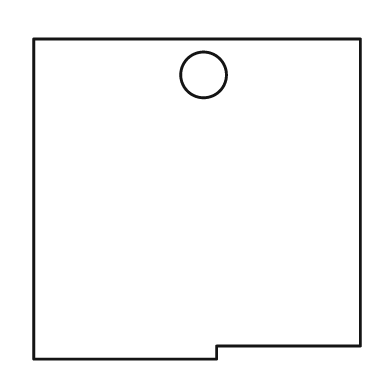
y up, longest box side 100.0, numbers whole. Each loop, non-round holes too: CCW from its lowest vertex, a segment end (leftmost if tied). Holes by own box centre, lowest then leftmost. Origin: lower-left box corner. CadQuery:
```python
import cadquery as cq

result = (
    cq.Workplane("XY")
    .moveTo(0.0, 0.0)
    .lineTo(56.0, 0.0)
    .lineTo(56.0, 4.0)
    .lineTo(100.0, 4.0)
    .lineTo(100.0, 98.0)
    .lineTo(0.0, 98.0)
    .close()
    .moveTo(52.0, 87.0)
    .circle(7.0)
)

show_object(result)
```